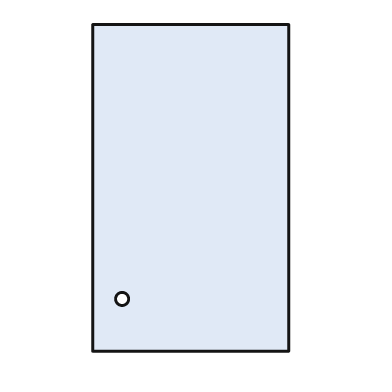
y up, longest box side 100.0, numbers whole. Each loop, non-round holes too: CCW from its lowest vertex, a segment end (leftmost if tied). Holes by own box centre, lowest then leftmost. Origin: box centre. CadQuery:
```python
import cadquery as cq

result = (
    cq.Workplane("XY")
    .moveTo(-30.0, -50.0)
    .lineTo(30.0, -50.0)
    .lineTo(30.0, 50.0)
    .lineTo(-30.0, 50.0)
    .close()
    .moveTo(-21.0, -34.0)
    .circle(2.0)
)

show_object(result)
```